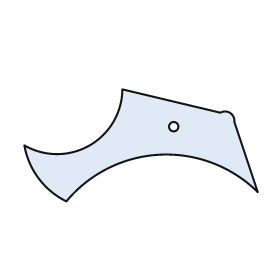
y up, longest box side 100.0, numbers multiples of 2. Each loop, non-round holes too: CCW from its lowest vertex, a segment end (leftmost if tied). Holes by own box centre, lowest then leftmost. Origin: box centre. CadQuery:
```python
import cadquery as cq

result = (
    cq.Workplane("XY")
    .moveTo(-32.0, -24.0)
    .threePointArc((8.0, -4.0), (50.0, -20.0))
    .lineTo(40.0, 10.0)
    .threePointArc((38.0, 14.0), (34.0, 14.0))
    .lineTo(-8.0, 24.0)
    .threePointArc((-22.0, 0.0), (-50.0, 0.0))
    .threePointArc((-44.0, -14.0), (-32.0, -24.0))
    .close()
    .moveTo(14.0, 8.0)
    .circle(2.0)
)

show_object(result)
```